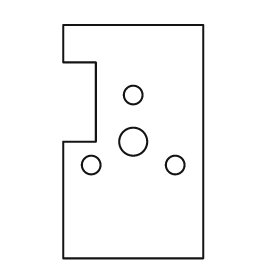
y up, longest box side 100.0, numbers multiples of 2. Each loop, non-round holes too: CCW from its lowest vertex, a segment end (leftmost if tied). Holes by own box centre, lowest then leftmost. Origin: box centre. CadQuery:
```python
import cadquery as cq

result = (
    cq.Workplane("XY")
    .moveTo(-30.0, -50.0)
    .lineTo(30.0, -50.0)
    .lineTo(30.0, 50.0)
    .lineTo(-30.0, 50.0)
    .lineTo(-30.0, 34.0)
    .lineTo(-16.0, 34.0)
    .lineTo(-16.0, 0.0)
    .lineTo(-30.0, 0.0)
    .close()
    .moveTo(-18.0, -10.0)
    .circle(4.0)
    .moveTo(18.0, -10.0)
    .circle(4.0)
    .moveTo(0.0, 0.0)
    .circle(6.0)
    .moveTo(0.0, 20.0)
    .circle(4.0)
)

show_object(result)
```